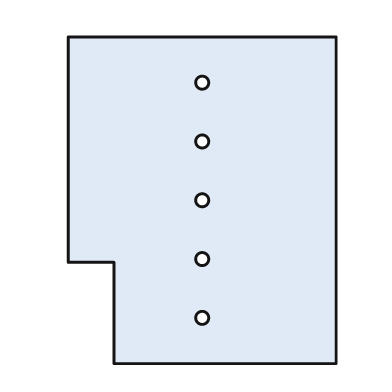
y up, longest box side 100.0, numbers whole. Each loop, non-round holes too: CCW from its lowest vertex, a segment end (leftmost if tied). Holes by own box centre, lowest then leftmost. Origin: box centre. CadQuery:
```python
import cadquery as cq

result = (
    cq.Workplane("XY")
    .moveTo(-27.0, -50.0)
    .lineTo(41.0, -50.0)
    .lineTo(41.0, 50.0)
    .lineTo(-41.0, 50.0)
    .lineTo(-41.0, -19.0)
    .lineTo(-27.0, -19.0)
    .close()
    .moveTo(0.0, -36.0)
    .circle(2.0)
    .moveTo(0.0, -18.0)
    .circle(2.0)
    .moveTo(0.0, 0.0)
    .circle(2.0)
    .moveTo(0.0, 18.0)
    .circle(2.0)
    .moveTo(0.0, 36.0)
    .circle(2.0)
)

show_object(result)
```